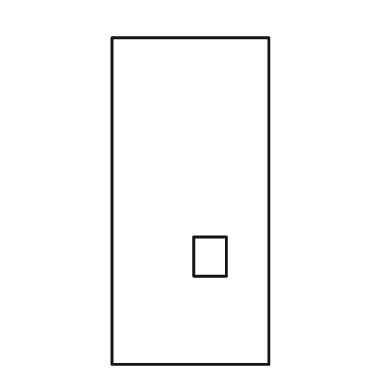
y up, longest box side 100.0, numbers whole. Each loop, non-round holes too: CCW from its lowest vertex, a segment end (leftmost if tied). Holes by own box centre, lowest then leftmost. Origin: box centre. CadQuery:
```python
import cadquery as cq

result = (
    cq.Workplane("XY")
    .moveTo(-24.0, -50.0)
    .lineTo(24.0, -50.0)
    .lineTo(24.0, 50.0)
    .lineTo(-24.0, 50.0)
    .close()
    .moveTo(1.0, -23.0)
    .lineTo(11.0, -23.0)
    .lineTo(11.0, -11.0)
    .lineTo(1.0, -11.0)
    .close()
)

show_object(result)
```